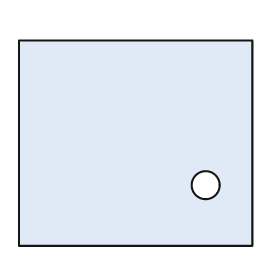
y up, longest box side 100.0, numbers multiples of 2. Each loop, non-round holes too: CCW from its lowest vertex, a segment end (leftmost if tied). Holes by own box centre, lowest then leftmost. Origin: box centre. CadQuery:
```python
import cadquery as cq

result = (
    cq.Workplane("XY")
    .moveTo(-50.0, -44.0)
    .lineTo(50.0, -44.0)
    .lineTo(50.0, 44.0)
    .lineTo(-50.0, 44.0)
    .close()
    .moveTo(30.0, -18.0)
    .circle(6.0)
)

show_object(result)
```